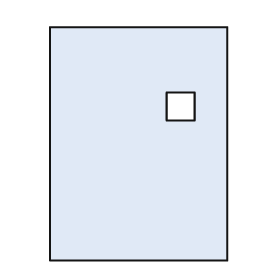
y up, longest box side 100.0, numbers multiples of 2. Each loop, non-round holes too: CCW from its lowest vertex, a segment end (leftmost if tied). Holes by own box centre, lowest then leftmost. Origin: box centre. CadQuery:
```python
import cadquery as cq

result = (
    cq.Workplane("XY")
    .moveTo(-38.0, -50.0)
    .lineTo(38.0, -50.0)
    .lineTo(38.0, 50.0)
    .lineTo(-38.0, 50.0)
    .close()
    .moveTo(12.0, 10.0)
    .lineTo(24.0, 10.0)
    .lineTo(24.0, 22.0)
    .lineTo(12.0, 22.0)
    .close()
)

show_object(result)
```